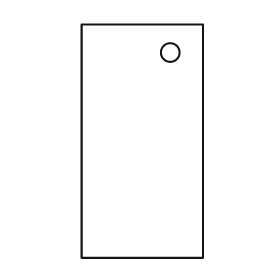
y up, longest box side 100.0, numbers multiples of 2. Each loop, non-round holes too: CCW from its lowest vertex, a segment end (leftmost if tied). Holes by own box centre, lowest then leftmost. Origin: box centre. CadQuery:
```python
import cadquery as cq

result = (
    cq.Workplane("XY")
    .moveTo(-26.0, -50.0)
    .lineTo(26.0, -50.0)
    .lineTo(26.0, 50.0)
    .lineTo(-26.0, 50.0)
    .close()
    .moveTo(12.0, 38.0)
    .circle(4.0)
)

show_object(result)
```